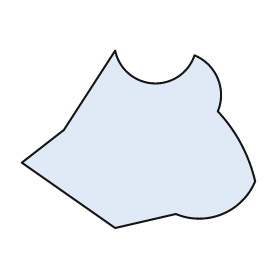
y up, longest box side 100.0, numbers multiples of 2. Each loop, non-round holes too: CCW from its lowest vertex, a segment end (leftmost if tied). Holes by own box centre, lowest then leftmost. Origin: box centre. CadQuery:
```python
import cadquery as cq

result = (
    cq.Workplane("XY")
    .moveTo(-10.0, -38.0)
    .lineTo(16.0, -32.0)
    .threePointArc((36.0, -32.0), (50.0, -18.0))
    .threePointArc((44.0, -2.0), (34.0, 12.0))
    .threePointArc((34.0, 26.0), (24.0, 36.0))
    .threePointArc((6.0, 24.0), (-10.0, 38.0))
    .lineTo(-32.0, 4.0)
    .lineTo(-50.0, -10.0)
    .close()
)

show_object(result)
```